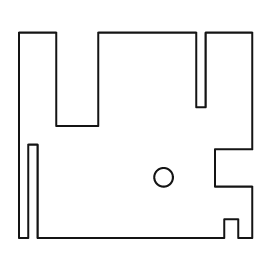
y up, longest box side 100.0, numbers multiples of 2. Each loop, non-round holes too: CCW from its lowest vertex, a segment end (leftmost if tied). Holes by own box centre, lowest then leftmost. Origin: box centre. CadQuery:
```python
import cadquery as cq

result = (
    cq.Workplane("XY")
    .moveTo(-50.0, -44.0)
    .lineTo(-46.0, -44.0)
    .lineTo(-46.0, -4.0)
    .lineTo(-42.0, -4.0)
    .lineTo(-42.0, -44.0)
    .lineTo(38.0, -44.0)
    .lineTo(38.0, -36.0)
    .lineTo(44.0, -36.0)
    .lineTo(44.0, -44.0)
    .lineTo(50.0, -44.0)
    .lineTo(50.0, -22.0)
    .lineTo(34.0, -22.0)
    .lineTo(34.0, -6.0)
    .lineTo(50.0, -6.0)
    .lineTo(50.0, 44.0)
    .lineTo(30.0, 44.0)
    .lineTo(30.0, 12.0)
    .lineTo(26.0, 12.0)
    .lineTo(26.0, 44.0)
    .lineTo(-16.0, 44.0)
    .lineTo(-16.0, 4.0)
    .lineTo(-34.0, 4.0)
    .lineTo(-34.0, 44.0)
    .lineTo(-50.0, 44.0)
    .close()
    .moveTo(12.0, -18.0)
    .circle(4.0)
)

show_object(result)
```